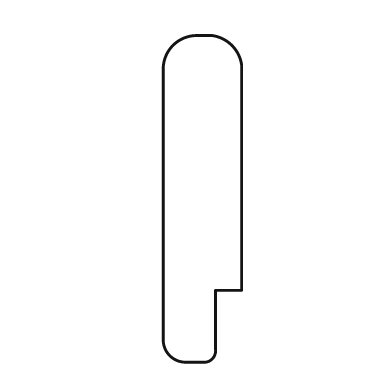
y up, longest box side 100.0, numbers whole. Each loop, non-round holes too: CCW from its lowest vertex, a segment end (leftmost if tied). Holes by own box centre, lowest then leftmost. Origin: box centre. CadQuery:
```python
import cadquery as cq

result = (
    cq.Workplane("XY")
    .moveTo(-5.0, -50.0)
    .lineTo(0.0, -50.0)
    .threePointArc((3.0, -49.0), (4.0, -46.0))
    .lineTo(4.0, -28.0)
    .lineTo(12.0, -28.0)
    .lineTo(12.0, 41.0)
    .threePointArc((9.0, 47.0), (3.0, 50.0))
    .lineTo(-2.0, 50.0)
    .threePointArc((-9.0, 47.0), (-12.0, 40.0))
    .lineTo(-12.0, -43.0)
    .threePointArc((-10.0, -48.0), (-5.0, -50.0))
    .close()
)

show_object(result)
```